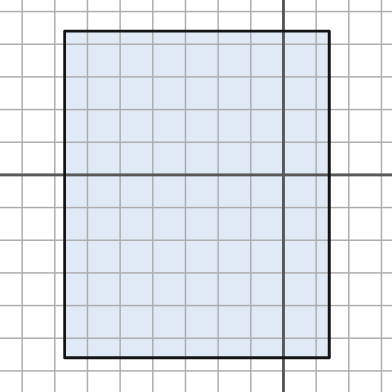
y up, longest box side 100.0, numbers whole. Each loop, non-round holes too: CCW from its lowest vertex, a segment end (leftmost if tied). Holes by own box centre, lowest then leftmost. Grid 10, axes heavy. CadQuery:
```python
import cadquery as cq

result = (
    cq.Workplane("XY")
    .moveTo(-67.0, -56.0)
    .lineTo(14.0, -56.0)
    .lineTo(14.0, 44.0)
    .lineTo(-67.0, 44.0)
    .close()
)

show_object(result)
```